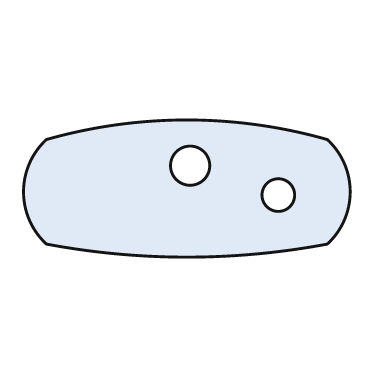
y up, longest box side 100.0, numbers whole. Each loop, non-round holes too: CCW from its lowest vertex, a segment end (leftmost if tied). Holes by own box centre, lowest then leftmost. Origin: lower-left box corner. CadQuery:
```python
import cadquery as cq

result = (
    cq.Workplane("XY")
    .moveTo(7.0, 4.0)
    .threePointArc((50.0, 0.0), (93.0, 4.0))
    .threePointArc((100.0, 20.0), (93.0, 36.0))
    .threePointArc((50.0, 42.0), (7.0, 36.0))
    .threePointArc((0.0, 20.0), (7.0, 4.0))
    .close()
    .moveTo(78.0, 19.0)
    .circle(5.0)
    .moveTo(51.0, 28.0)
    .circle(6.0)
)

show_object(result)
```